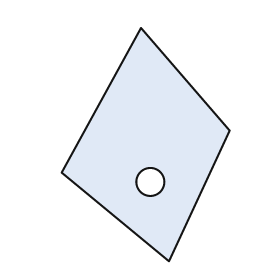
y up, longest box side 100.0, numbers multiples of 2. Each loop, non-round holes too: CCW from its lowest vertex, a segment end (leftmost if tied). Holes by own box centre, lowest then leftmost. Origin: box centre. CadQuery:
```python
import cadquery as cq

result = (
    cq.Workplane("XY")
    .moveTo(10.0, -50.0)
    .lineTo(36.0, 6.0)
    .lineTo(-2.0, 50.0)
    .lineTo(-36.0, -12.0)
    .close()
    .moveTo(2.0, -16.0)
    .circle(6.0)
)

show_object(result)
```